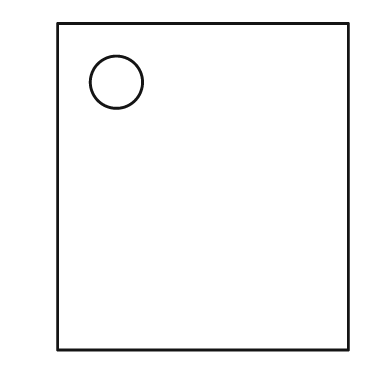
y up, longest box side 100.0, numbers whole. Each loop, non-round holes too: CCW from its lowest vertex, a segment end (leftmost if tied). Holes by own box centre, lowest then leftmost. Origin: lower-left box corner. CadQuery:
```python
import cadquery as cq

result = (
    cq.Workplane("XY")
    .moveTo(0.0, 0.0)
    .lineTo(89.0, 0.0)
    .lineTo(89.0, 100.0)
    .lineTo(0.0, 100.0)
    .close()
    .moveTo(18.0, 82.0)
    .circle(8.0)
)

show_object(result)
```